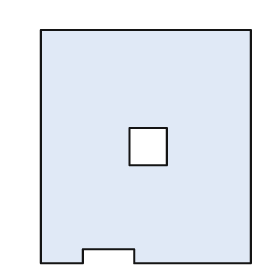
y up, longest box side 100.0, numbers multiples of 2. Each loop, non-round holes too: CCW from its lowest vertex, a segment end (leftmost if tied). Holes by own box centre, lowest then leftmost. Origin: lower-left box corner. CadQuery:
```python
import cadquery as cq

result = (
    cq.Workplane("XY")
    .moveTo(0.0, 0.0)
    .lineTo(18.0, 0.0)
    .lineTo(18.0, 6.0)
    .lineTo(40.0, 6.0)
    .lineTo(40.0, 0.0)
    .lineTo(90.0, 0.0)
    .lineTo(90.0, 100.0)
    .lineTo(0.0, 100.0)
    .close()
    .moveTo(38.0, 42.0)
    .lineTo(54.0, 42.0)
    .lineTo(54.0, 58.0)
    .lineTo(38.0, 58.0)
    .close()
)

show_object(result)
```